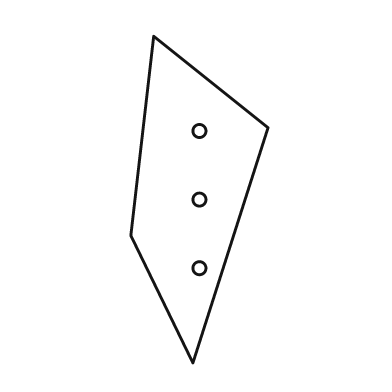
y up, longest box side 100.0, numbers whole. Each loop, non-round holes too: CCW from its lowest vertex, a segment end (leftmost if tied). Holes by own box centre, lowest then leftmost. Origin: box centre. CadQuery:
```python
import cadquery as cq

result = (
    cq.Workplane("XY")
    .moveTo(-2.0, -50.0)
    .lineTo(21.0, 22.0)
    .lineTo(-14.0, 50.0)
    .lineTo(-21.0, -11.0)
    .close()
    .moveTo(0.0, -21.0)
    .circle(2.0)
    .moveTo(0.0, 0.0)
    .circle(2.0)
    .moveTo(0.0, 21.0)
    .circle(2.0)
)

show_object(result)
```